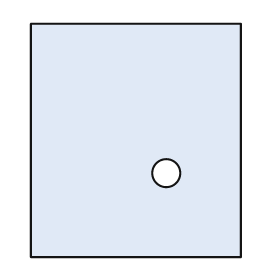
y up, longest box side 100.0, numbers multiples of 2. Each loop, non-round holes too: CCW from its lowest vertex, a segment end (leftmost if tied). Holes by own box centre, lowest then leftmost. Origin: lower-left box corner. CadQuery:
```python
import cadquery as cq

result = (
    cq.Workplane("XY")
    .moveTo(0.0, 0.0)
    .lineTo(90.0, 0.0)
    .lineTo(90.0, 100.0)
    .lineTo(0.0, 100.0)
    .close()
    .moveTo(58.0, 36.0)
    .circle(6.0)
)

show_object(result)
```